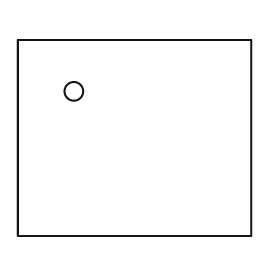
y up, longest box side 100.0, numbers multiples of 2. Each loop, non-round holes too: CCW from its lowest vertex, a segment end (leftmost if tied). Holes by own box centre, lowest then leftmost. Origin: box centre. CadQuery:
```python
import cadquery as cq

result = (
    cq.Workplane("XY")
    .moveTo(-50.0, -42.0)
    .lineTo(50.0, -42.0)
    .lineTo(50.0, 42.0)
    .lineTo(-50.0, 42.0)
    .close()
    .moveTo(-26.0, 20.0)
    .circle(4.0)
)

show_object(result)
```